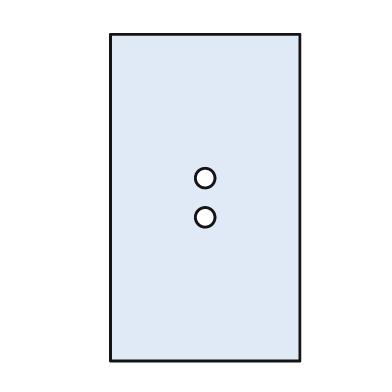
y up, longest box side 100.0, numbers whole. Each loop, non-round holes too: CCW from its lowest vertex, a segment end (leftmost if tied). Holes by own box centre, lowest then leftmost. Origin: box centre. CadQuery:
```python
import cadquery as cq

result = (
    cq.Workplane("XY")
    .moveTo(-29.0, -50.0)
    .lineTo(29.0, -50.0)
    .lineTo(29.0, 50.0)
    .lineTo(-29.0, 50.0)
    .close()
    .moveTo(0.0, -6.0)
    .circle(3.0)
    .moveTo(0.0, 6.0)
    .circle(3.0)
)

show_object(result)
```